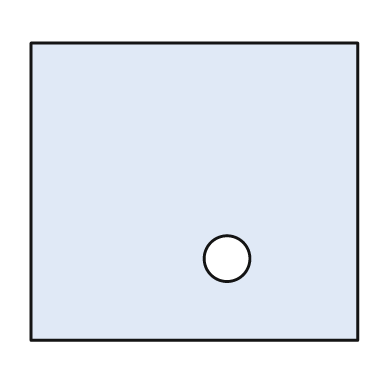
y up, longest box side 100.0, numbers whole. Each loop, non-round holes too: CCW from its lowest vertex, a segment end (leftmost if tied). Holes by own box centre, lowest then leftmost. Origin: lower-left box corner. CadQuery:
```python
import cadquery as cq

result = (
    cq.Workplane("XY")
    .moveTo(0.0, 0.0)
    .lineTo(100.0, 0.0)
    .lineTo(100.0, 91.0)
    .lineTo(0.0, 91.0)
    .close()
    .moveTo(60.0, 25.0)
    .circle(7.0)
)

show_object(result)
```